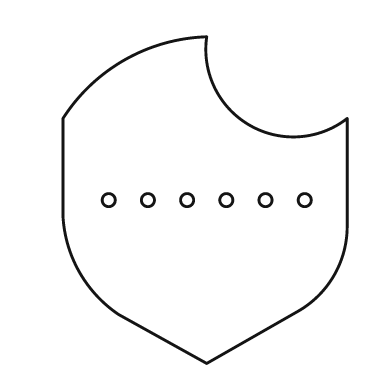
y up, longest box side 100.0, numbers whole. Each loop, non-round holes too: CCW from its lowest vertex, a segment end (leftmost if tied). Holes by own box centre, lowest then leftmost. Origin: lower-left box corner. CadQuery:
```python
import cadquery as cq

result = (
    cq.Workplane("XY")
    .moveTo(44.0, 0.0)
    .lineTo(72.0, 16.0)
    .threePointArc((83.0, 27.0), (87.0, 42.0))
    .lineTo(87.0, 75.0)
    .threePointArc((57.0, 73.0), (44.0, 100.0))
    .threePointArc((19.0, 93.0), (0.0, 75.0))
    .lineTo(0.0, 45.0)
    .threePointArc((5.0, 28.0), (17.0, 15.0))
    .close()
    .moveTo(14.0, 50.0)
    .circle(2.0)
    .moveTo(26.0, 50.0)
    .circle(2.0)
    .moveTo(38.0, 50.0)
    .circle(2.0)
    .moveTo(50.0, 50.0)
    .circle(2.0)
    .moveTo(62.0, 50.0)
    .circle(2.0)
    .moveTo(74.0, 50.0)
    .circle(2.0)
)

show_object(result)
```